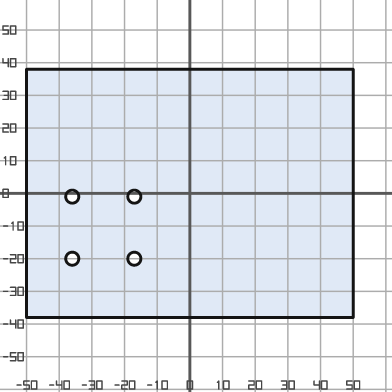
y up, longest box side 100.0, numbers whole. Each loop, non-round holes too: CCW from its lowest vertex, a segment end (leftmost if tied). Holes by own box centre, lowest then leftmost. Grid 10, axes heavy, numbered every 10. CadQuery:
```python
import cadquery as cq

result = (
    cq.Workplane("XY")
    .moveTo(-50.0, -38.0)
    .lineTo(50.0, -38.0)
    .lineTo(50.0, 38.0)
    .lineTo(-50.0, 38.0)
    .close()
    .moveTo(-36.0, -20.0)
    .circle(2.0)
    .moveTo(-17.0, -20.0)
    .circle(2.0)
    .moveTo(-36.0, -1.0)
    .circle(2.0)
    .moveTo(-17.0, -1.0)
    .circle(2.0)
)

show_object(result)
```